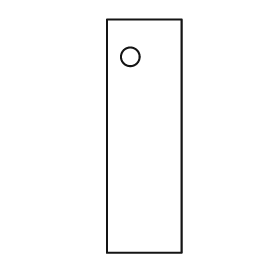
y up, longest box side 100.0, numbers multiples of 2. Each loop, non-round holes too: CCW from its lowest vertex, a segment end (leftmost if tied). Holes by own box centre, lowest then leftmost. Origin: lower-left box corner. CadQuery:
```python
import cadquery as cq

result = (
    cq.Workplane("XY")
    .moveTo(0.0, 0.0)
    .lineTo(32.0, 0.0)
    .lineTo(32.0, 100.0)
    .lineTo(0.0, 100.0)
    .close()
    .moveTo(10.0, 84.0)
    .circle(4.0)
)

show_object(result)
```